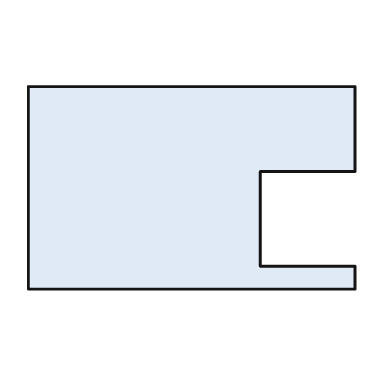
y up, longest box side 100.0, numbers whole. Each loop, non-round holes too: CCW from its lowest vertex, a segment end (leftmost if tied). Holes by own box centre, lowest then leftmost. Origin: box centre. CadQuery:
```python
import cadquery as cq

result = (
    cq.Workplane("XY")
    .moveTo(-50.0, -31.0)
    .lineTo(50.0, -31.0)
    .lineTo(50.0, -24.0)
    .lineTo(21.0, -24.0)
    .lineTo(21.0, 5.0)
    .lineTo(50.0, 5.0)
    .lineTo(50.0, 31.0)
    .lineTo(-50.0, 31.0)
    .close()
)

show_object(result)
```